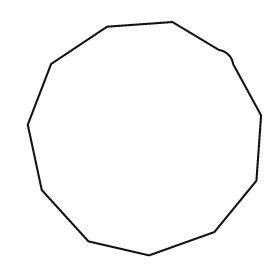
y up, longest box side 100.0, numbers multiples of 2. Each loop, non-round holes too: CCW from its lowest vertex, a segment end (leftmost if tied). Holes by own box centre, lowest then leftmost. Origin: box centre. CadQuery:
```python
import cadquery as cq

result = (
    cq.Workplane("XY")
    .moveTo(2.0, -50.0)
    .lineTo(30.0, -40.0)
    .lineTo(48.0, -18.0)
    .lineTo(50.0, 10.0)
    .lineTo(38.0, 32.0)
    .threePointArc((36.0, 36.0), (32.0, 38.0))
    .lineTo(12.0, 50.0)
    .lineTo(-16.0, 48.0)
    .lineTo(-40.0, 32.0)
    .lineTo(-50.0, 6.0)
    .lineTo(-44.0, -22.0)
    .lineTo(-24.0, -44.0)
    .close()
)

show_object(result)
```